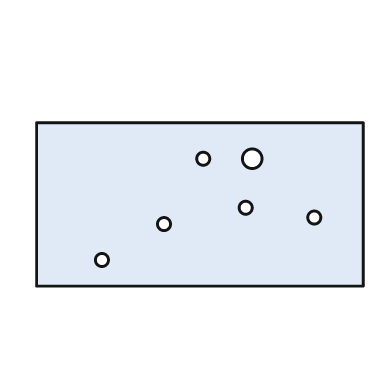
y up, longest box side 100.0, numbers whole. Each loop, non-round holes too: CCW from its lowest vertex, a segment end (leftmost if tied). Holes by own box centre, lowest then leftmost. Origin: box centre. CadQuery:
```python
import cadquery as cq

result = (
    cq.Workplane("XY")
    .moveTo(-50.0, -25.0)
    .lineTo(50.0, -25.0)
    .lineTo(50.0, 25.0)
    .lineTo(-50.0, 25.0)
    .close()
    .moveTo(-30.0, -17.0)
    .circle(2.0)
    .moveTo(-11.0, -6.0)
    .circle(2.0)
    .moveTo(35.0, -4.0)
    .circle(2.0)
    .moveTo(14.0, -1.0)
    .circle(2.0)
    .moveTo(1.0, 14.0)
    .circle(2.0)
    .moveTo(16.0, 14.0)
    .circle(3.0)
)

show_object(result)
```